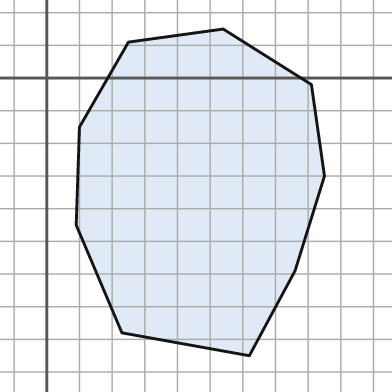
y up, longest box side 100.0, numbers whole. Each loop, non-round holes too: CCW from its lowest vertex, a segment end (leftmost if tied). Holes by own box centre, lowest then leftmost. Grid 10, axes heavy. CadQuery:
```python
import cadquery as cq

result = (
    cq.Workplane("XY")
    .moveTo(62.0, -85.0)
    .lineTo(76.0, -59.0)
    .lineTo(85.0, -30.0)
    .lineTo(81.0, -2.0)
    .lineTo(54.0, 15.0)
    .lineTo(25.0, 11.0)
    .lineTo(10.0, -15.0)
    .lineTo(9.0, -45.0)
    .lineTo(23.0, -78.0)
    .close()
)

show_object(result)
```